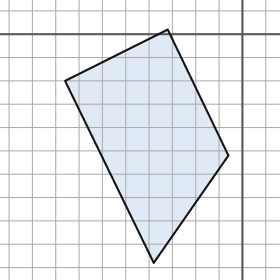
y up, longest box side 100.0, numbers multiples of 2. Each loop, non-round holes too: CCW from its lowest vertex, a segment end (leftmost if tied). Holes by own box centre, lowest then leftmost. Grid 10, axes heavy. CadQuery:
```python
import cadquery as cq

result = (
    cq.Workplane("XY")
    .moveTo(-38.0, -98.0)
    .lineTo(-6.0, -52.0)
    .lineTo(-32.0, 2.0)
    .lineTo(-76.0, -20.0)
    .close()
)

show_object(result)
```